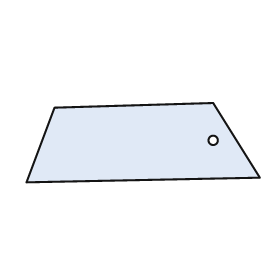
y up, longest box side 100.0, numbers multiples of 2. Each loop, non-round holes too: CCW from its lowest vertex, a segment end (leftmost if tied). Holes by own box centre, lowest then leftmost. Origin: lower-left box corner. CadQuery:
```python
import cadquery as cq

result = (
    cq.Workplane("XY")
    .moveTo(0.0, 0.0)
    .lineTo(100.0, 2.0)
    .lineTo(80.0, 34.0)
    .lineTo(12.0, 32.0)
    .close()
    .moveTo(80.0, 18.0)
    .circle(2.0)
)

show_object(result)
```